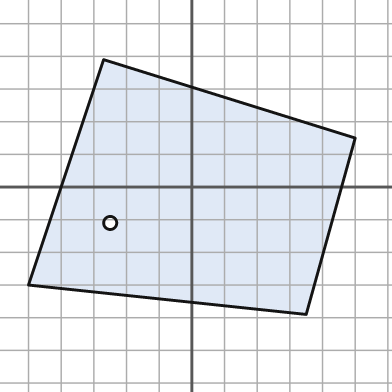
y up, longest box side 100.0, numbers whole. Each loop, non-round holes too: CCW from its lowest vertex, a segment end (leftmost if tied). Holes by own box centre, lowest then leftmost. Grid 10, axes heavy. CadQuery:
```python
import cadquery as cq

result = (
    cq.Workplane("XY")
    .moveTo(35.0, -39.0)
    .lineTo(50.0, 15.0)
    .lineTo(-27.0, 39.0)
    .lineTo(-50.0, -30.0)
    .close()
    .moveTo(-25.0, -11.0)
    .circle(2.0)
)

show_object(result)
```